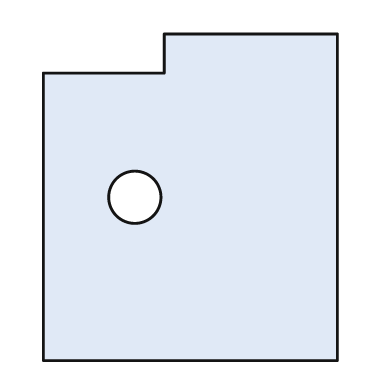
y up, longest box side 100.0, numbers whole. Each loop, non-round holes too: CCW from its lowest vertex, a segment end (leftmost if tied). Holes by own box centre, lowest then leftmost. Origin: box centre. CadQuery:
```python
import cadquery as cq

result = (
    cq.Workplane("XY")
    .moveTo(-45.0, -50.0)
    .lineTo(45.0, -50.0)
    .lineTo(45.0, 50.0)
    .lineTo(-8.0, 50.0)
    .lineTo(-8.0, 38.0)
    .lineTo(-45.0, 38.0)
    .close()
    .moveTo(-17.0, 0.0)
    .circle(8.0)
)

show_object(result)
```